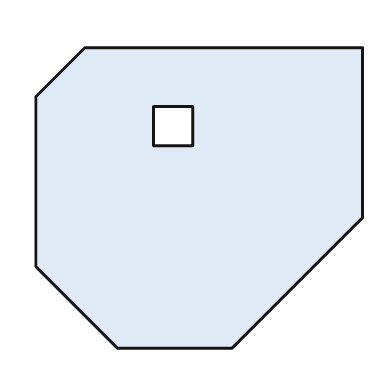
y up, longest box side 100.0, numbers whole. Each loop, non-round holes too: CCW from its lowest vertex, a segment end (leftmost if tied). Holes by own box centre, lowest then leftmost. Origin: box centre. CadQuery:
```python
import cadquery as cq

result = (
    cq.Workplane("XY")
    .moveTo(-25.0, -46.0)
    .lineTo(10.0, -46.0)
    .lineTo(50.0, -6.0)
    .lineTo(50.0, 46.0)
    .lineTo(-35.0, 46.0)
    .lineTo(-50.0, 31.0)
    .lineTo(-50.0, -21.0)
    .close()
    .moveTo(-14.0, 16.0)
    .lineTo(-2.0, 16.0)
    .lineTo(-2.0, 28.0)
    .lineTo(-14.0, 28.0)
    .close()
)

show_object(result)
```